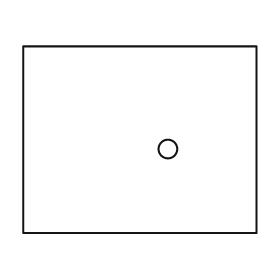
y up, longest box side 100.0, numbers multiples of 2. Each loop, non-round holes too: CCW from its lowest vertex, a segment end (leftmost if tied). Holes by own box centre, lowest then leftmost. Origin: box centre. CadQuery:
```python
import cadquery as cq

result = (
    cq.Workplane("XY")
    .moveTo(-50.0, -40.0)
    .lineTo(50.0, -40.0)
    .lineTo(50.0, 40.0)
    .lineTo(-50.0, 40.0)
    .close()
    .moveTo(12.0, -4.0)
    .circle(4.0)
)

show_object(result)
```